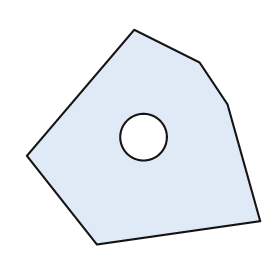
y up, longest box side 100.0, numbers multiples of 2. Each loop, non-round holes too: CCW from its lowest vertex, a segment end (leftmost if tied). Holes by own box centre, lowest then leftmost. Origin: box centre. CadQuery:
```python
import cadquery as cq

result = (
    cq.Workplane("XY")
    .moveTo(-20.0, -46.0)
    .lineTo(50.0, -36.0)
    .lineTo(36.0, 14.0)
    .lineTo(24.0, 32.0)
    .lineTo(-4.0, 46.0)
    .lineTo(-50.0, -8.0)
    .close()
    .moveTo(0.0, 0.0)
    .circle(10.0)
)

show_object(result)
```